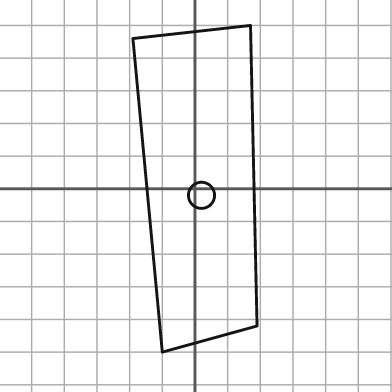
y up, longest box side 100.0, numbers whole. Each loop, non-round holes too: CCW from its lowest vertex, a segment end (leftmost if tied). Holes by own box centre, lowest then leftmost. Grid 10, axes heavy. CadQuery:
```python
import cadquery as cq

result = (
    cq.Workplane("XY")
    .moveTo(-10.0, -50.0)
    .lineTo(19.0, -42.0)
    .lineTo(17.0, 50.0)
    .lineTo(-19.0, 46.0)
    .close()
    .moveTo(2.0, -2.0)
    .circle(4.0)
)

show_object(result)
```